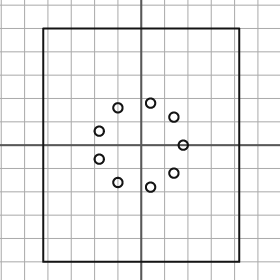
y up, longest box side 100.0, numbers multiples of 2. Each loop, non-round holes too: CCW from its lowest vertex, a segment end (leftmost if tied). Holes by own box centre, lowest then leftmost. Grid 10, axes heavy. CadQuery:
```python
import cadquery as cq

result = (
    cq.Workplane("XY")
    .moveTo(-42.0, -50.0)
    .lineTo(42.0, -50.0)
    .lineTo(42.0, 50.0)
    .lineTo(-42.0, 50.0)
    .close()
    .moveTo(4.0, -18.0)
    .circle(2.0)
    .moveTo(-10.0, -16.0)
    .circle(2.0)
    .moveTo(14.0, -12.0)
    .circle(2.0)
    .moveTo(-18.0, -6.0)
    .circle(2.0)
    .moveTo(18.0, 0.0)
    .circle(2.0)
    .moveTo(-18.0, 6.0)
    .circle(2.0)
    .moveTo(14.0, 12.0)
    .circle(2.0)
    .moveTo(-10.0, 16.0)
    .circle(2.0)
    .moveTo(4.0, 18.0)
    .circle(2.0)
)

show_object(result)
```